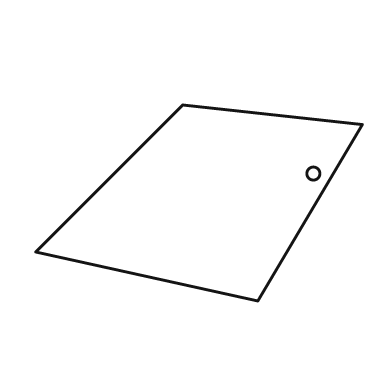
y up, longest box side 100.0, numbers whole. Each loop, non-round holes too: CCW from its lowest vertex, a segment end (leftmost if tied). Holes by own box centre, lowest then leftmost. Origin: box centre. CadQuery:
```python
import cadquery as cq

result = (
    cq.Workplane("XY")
    .moveTo(18.0, -30.0)
    .lineTo(50.0, 24.0)
    .lineTo(-5.0, 30.0)
    .lineTo(-50.0, -15.0)
    .close()
    .moveTo(35.0, 9.0)
    .circle(2.0)
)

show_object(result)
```